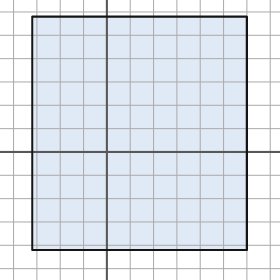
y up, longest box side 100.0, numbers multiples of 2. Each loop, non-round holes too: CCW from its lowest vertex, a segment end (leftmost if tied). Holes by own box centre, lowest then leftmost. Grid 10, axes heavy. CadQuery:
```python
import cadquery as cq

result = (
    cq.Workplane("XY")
    .moveTo(-32.0, -42.0)
    .lineTo(60.0, -42.0)
    .lineTo(60.0, 58.0)
    .lineTo(-32.0, 58.0)
    .close()
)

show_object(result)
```